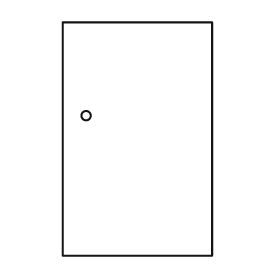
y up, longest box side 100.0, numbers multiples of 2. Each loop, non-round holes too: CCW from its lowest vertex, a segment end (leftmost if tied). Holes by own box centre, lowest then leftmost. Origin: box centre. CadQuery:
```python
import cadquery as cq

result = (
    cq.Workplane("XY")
    .moveTo(-32.0, -50.0)
    .lineTo(32.0, -50.0)
    .lineTo(32.0, 50.0)
    .lineTo(-32.0, 50.0)
    .close()
    .moveTo(-22.0, 10.0)
    .circle(2.0)
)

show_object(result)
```